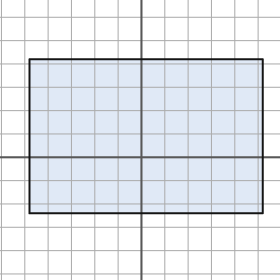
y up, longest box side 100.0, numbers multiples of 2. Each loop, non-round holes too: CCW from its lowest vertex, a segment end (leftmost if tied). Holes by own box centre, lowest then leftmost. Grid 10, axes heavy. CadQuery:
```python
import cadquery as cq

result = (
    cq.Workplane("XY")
    .moveTo(-48.0, -24.0)
    .lineTo(52.0, -24.0)
    .lineTo(52.0, 42.0)
    .lineTo(-48.0, 42.0)
    .close()
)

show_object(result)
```